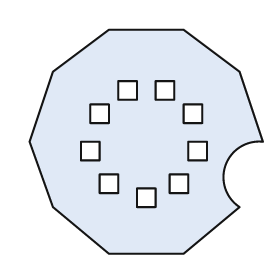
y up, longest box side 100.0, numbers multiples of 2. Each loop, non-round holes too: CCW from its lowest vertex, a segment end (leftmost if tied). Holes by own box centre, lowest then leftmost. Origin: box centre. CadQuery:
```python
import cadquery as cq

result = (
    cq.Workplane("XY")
    .moveTo(-16.0, -48.0)
    .lineTo(16.0, -48.0)
    .lineTo(40.0, -28.0)
    .threePointArc((34.0, -10.0), (50.0, 0.0))
    .lineTo(40.0, 30.0)
    .lineTo(16.0, 48.0)
    .lineTo(-16.0, 48.0)
    .lineTo(-40.0, 30.0)
    .lineTo(-50.0, 0.0)
    .lineTo(-40.0, -28.0)
    .close()
    .moveTo(-4.0, -28.0)
    .lineTo(4.0, -28.0)
    .lineTo(4.0, -20.0)
    .lineTo(-4.0, -20.0)
    .close()
    .moveTo(-20.0, -22.0)
    .lineTo(-12.0, -22.0)
    .lineTo(-12.0, -14.0)
    .lineTo(-20.0, -14.0)
    .close()
    .moveTo(10.0, -22.0)
    .lineTo(18.0, -22.0)
    .lineTo(18.0, -14.0)
    .lineTo(10.0, -14.0)
    .close()
    .moveTo(-28.0, -8.0)
    .lineTo(-20.0, -8.0)
    .lineTo(-20.0, 0.0)
    .lineTo(-28.0, 0.0)
    .close()
    .moveTo(18.0, -8.0)
    .lineTo(26.0, -8.0)
    .lineTo(26.0, 0.0)
    .lineTo(18.0, 0.0)
    .close()
    .moveTo(-24.0, 8.0)
    .lineTo(-16.0, 8.0)
    .lineTo(-16.0, 16.0)
    .lineTo(-24.0, 16.0)
    .close()
    .moveTo(16.0, 8.0)
    .lineTo(24.0, 8.0)
    .lineTo(24.0, 16.0)
    .lineTo(16.0, 16.0)
    .close()
    .moveTo(-12.0, 18.0)
    .lineTo(-4.0, 18.0)
    .lineTo(-4.0, 26.0)
    .lineTo(-12.0, 26.0)
    .close()
    .moveTo(4.0, 18.0)
    .lineTo(12.0, 18.0)
    .lineTo(12.0, 26.0)
    .lineTo(4.0, 26.0)
    .close()
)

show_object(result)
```